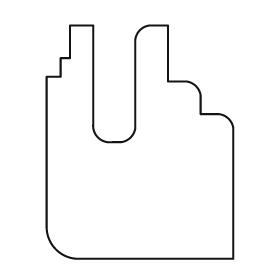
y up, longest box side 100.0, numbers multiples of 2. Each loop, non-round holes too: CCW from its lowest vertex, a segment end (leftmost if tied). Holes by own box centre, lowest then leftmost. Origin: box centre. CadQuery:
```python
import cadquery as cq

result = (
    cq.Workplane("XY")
    .moveTo(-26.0, -50.0)
    .lineTo(40.0, -50.0)
    .lineTo(40.0, 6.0)
    .threePointArc((38.0, 10.0), (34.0, 12.0))
    .lineTo(26.0, 12.0)
    .lineTo(26.0, 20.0)
    .threePointArc((24.0, 24.0), (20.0, 26.0))
    .lineTo(12.0, 26.0)
    .lineTo(12.0, 50.0)
    .lineTo(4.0, 50.0)
    .threePointArc((0.0, 48.0), (-2.0, 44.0))
    .lineTo(-2.0, 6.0)
    .threePointArc((-4.0, 2.0), (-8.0, 0.0))
    .lineTo(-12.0, 0.0)
    .threePointArc((-18.0, 2.0), (-20.0, 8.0))
    .lineTo(-20.0, 50.0)
    .lineTo(-30.0, 50.0)
    .lineTo(-30.0, 36.0)
    .lineTo(-34.0, 36.0)
    .lineTo(-34.0, 28.0)
    .lineTo(-40.0, 28.0)
    .lineTo(-40.0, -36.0)
    .threePointArc((-36.0, -46.0), (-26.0, -50.0))
    .close()
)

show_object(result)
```